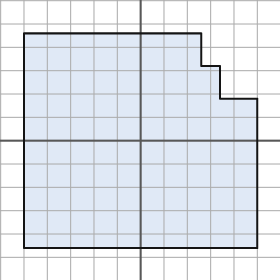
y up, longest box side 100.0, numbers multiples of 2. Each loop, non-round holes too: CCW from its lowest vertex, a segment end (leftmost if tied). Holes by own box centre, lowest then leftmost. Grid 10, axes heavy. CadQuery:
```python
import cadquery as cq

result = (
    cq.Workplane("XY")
    .moveTo(-50.0, -46.0)
    .lineTo(50.0, -46.0)
    .lineTo(50.0, 18.0)
    .lineTo(34.0, 18.0)
    .lineTo(34.0, 32.0)
    .lineTo(26.0, 32.0)
    .lineTo(26.0, 46.0)
    .lineTo(-50.0, 46.0)
    .close()
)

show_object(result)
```